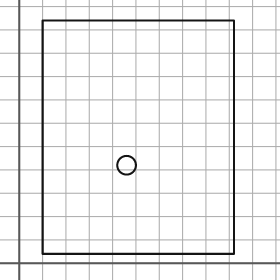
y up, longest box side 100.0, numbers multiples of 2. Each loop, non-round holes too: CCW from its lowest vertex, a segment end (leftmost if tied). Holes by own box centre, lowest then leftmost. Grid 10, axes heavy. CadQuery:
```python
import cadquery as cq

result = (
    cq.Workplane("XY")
    .moveTo(10.0, 4.0)
    .lineTo(92.0, 4.0)
    .lineTo(92.0, 104.0)
    .lineTo(10.0, 104.0)
    .close()
    .moveTo(46.0, 42.0)
    .circle(4.0)
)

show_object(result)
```